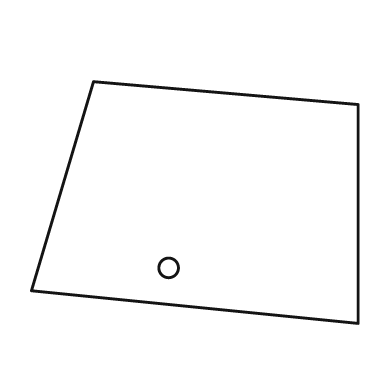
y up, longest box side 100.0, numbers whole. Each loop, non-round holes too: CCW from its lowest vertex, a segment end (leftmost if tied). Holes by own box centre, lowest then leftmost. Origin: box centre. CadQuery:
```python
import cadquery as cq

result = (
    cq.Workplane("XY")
    .moveTo(50.0, -37.0)
    .lineTo(50.0, 30.0)
    .lineTo(-31.0, 37.0)
    .lineTo(-50.0, -27.0)
    .close()
    .moveTo(-8.0, -20.0)
    .circle(3.0)
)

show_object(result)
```